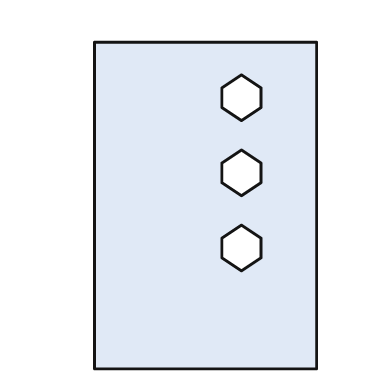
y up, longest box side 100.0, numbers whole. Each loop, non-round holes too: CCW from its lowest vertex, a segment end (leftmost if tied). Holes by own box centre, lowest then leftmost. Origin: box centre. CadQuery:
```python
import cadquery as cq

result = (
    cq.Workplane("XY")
    .moveTo(-34.0, -50.0)
    .lineTo(34.0, -50.0)
    .lineTo(34.0, 50.0)
    .lineTo(-34.0, 50.0)
    .close()
    .moveTo(11.0, -20.0)
    .lineTo(17.0, -16.0)
    .lineTo(17.0, -10.0)
    .lineTo(11.0, -6.0)
    .lineTo(5.0, -10.0)
    .lineTo(5.0, -16.0)
    .close()
    .moveTo(11.0, 3.0)
    .lineTo(17.0, 7.0)
    .lineTo(17.0, 13.0)
    .lineTo(11.0, 17.0)
    .lineTo(5.0, 13.0)
    .lineTo(5.0, 7.0)
    .close()
    .moveTo(11.0, 26.0)
    .lineTo(17.0, 30.0)
    .lineTo(17.0, 36.0)
    .lineTo(11.0, 40.0)
    .lineTo(5.0, 36.0)
    .lineTo(5.0, 30.0)
    .close()
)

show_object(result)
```